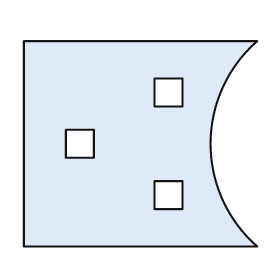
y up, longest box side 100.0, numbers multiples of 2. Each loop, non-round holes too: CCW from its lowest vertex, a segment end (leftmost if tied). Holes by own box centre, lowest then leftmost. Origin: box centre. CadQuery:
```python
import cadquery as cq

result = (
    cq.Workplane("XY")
    .moveTo(-50.0, -44.0)
    .lineTo(50.0, -44.0)
    .threePointArc((30.0, 0.0), (50.0, 44.0))
    .lineTo(-50.0, 44.0)
    .close()
    .moveTo(6.0, -28.0)
    .lineTo(18.0, -28.0)
    .lineTo(18.0, -16.0)
    .lineTo(6.0, -16.0)
    .close()
    .moveTo(-32.0, -6.0)
    .lineTo(-20.0, -6.0)
    .lineTo(-20.0, 6.0)
    .lineTo(-32.0, 6.0)
    .close()
    .moveTo(6.0, 16.0)
    .lineTo(18.0, 16.0)
    .lineTo(18.0, 28.0)
    .lineTo(6.0, 28.0)
    .close()
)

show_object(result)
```